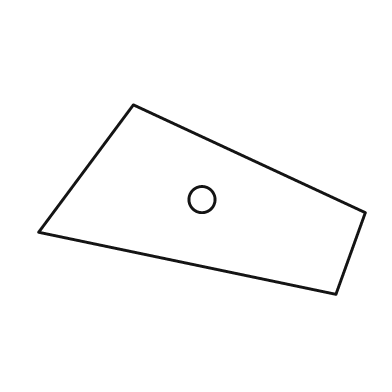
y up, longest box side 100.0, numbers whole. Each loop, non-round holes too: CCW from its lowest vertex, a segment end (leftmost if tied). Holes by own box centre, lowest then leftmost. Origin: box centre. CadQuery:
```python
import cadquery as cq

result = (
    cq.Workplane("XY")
    .moveTo(41.0, -29.0)
    .lineTo(50.0, -4.0)
    .lineTo(-21.0, 29.0)
    .lineTo(-50.0, -10.0)
    .close()
    .moveTo(0.0, 0.0)
    .circle(4.0)
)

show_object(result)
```